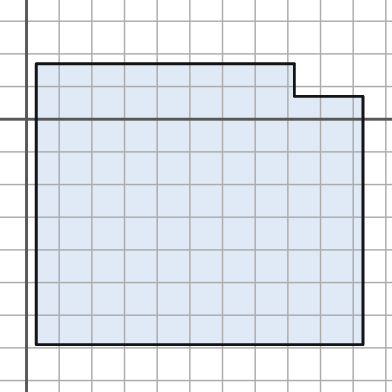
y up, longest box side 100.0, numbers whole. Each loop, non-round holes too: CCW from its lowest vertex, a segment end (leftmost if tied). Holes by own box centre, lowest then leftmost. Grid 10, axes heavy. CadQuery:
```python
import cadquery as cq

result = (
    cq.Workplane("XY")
    .moveTo(3.0, -69.0)
    .lineTo(103.0, -69.0)
    .lineTo(103.0, 7.0)
    .lineTo(82.0, 7.0)
    .lineTo(82.0, 17.0)
    .lineTo(3.0, 17.0)
    .close()
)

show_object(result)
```